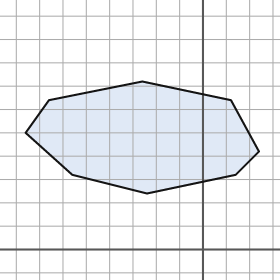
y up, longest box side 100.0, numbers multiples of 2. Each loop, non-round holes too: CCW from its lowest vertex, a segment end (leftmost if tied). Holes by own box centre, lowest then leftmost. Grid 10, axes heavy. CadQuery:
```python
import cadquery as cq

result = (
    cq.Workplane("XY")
    .moveTo(-24.0, 24.0)
    .lineTo(14.0, 32.0)
    .lineTo(24.0, 42.0)
    .lineTo(12.0, 64.0)
    .lineTo(-26.0, 72.0)
    .lineTo(-66.0, 64.0)
    .lineTo(-76.0, 50.0)
    .lineTo(-56.0, 32.0)
    .close()
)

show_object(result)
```